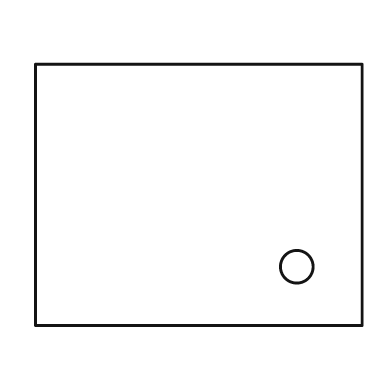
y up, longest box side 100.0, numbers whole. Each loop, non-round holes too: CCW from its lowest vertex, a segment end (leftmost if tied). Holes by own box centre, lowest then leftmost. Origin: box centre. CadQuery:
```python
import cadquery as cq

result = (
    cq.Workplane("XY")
    .moveTo(-50.0, -40.0)
    .lineTo(50.0, -40.0)
    .lineTo(50.0, 40.0)
    .lineTo(-50.0, 40.0)
    .close()
    .moveTo(30.0, -22.0)
    .circle(5.0)
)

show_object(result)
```